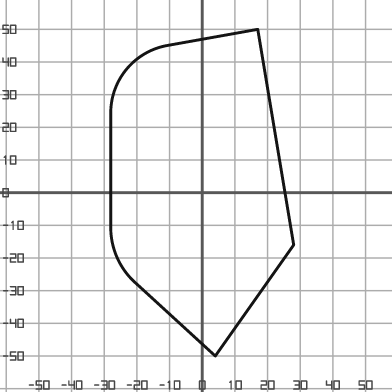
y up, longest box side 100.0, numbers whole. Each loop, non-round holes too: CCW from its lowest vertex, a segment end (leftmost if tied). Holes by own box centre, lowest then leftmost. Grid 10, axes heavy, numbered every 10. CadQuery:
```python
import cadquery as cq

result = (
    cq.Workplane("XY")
    .moveTo(4.0, -50.0)
    .lineTo(28.0, -16.0)
    .lineTo(17.0, 50.0)
    .lineTo(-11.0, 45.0)
    .threePointArc((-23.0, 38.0), (-28.0, 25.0))
    .lineTo(-28.0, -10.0)
    .threePointArc((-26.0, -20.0), (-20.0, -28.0))
    .close()
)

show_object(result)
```